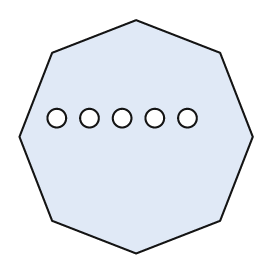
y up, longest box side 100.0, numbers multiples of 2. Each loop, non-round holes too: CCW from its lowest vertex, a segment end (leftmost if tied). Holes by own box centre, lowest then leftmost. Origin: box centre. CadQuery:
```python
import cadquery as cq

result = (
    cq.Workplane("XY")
    .moveTo(0.0, -50.0)
    .lineTo(36.0, -36.0)
    .lineTo(50.0, 0.0)
    .lineTo(36.0, 36.0)
    .lineTo(0.0, 50.0)
    .lineTo(-36.0, 36.0)
    .lineTo(-50.0, 0.0)
    .lineTo(-36.0, -36.0)
    .close()
    .moveTo(-34.0, 8.0)
    .circle(4.0)
    .moveTo(-20.0, 8.0)
    .circle(4.0)
    .moveTo(-6.0, 8.0)
    .circle(4.0)
    .moveTo(8.0, 8.0)
    .circle(4.0)
    .moveTo(22.0, 8.0)
    .circle(4.0)
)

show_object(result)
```